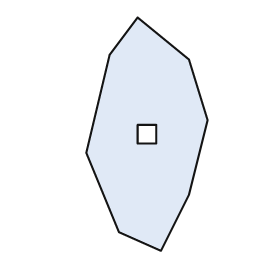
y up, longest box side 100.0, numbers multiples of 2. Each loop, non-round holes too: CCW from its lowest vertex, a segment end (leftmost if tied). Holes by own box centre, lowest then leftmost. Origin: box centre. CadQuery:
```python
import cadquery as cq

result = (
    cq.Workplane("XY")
    .moveTo(6.0, -50.0)
    .lineTo(18.0, -26.0)
    .lineTo(26.0, 6.0)
    .lineTo(18.0, 32.0)
    .lineTo(-4.0, 50.0)
    .lineTo(-16.0, 34.0)
    .lineTo(-26.0, -8.0)
    .lineTo(-12.0, -42.0)
    .close()
    .moveTo(-4.0, -4.0)
    .lineTo(4.0, -4.0)
    .lineTo(4.0, 4.0)
    .lineTo(-4.0, 4.0)
    .close()
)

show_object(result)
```